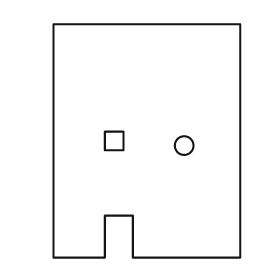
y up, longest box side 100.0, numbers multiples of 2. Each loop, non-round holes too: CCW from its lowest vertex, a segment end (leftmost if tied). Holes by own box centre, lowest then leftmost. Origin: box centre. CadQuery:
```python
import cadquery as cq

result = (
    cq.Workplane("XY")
    .moveTo(-40.0, -50.0)
    .lineTo(-18.0, -50.0)
    .lineTo(-18.0, -32.0)
    .lineTo(-6.0, -32.0)
    .lineTo(-6.0, -50.0)
    .lineTo(40.0, -50.0)
    .lineTo(40.0, 50.0)
    .lineTo(-40.0, 50.0)
    .close()
    .moveTo(16.0, -2.0)
    .circle(4.0)
    .moveTo(-18.0, -4.0)
    .lineTo(-10.0, -4.0)
    .lineTo(-10.0, 4.0)
    .lineTo(-18.0, 4.0)
    .close()
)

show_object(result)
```